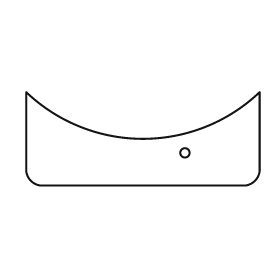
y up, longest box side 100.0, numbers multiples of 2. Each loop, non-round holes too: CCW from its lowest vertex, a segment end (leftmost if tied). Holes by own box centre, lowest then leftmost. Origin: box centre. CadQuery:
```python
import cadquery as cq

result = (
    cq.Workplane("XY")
    .moveTo(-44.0, -20.0)
    .lineTo(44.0, -20.0)
    .threePointArc((48.0, -18.0), (50.0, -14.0))
    .lineTo(50.0, 20.0)
    .threePointArc((0.0, 0.0), (-50.0, 20.0))
    .lineTo(-50.0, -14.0)
    .threePointArc((-48.0, -18.0), (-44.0, -20.0))
    .close()
    .moveTo(18.0, -6.0)
    .circle(2.0)
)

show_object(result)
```